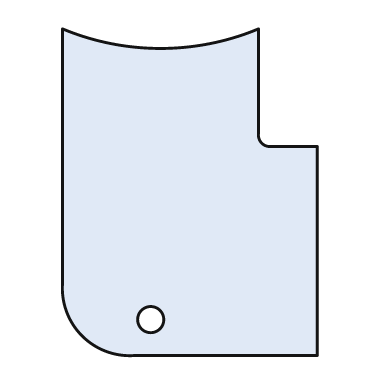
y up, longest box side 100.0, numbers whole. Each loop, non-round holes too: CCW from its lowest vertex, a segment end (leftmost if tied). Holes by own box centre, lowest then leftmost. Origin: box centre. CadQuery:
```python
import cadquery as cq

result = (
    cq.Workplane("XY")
    .moveTo(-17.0, -50.0)
    .lineTo(39.0, -50.0)
    .lineTo(39.0, 14.0)
    .lineTo(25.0, 14.0)
    .threePointArc((22.0, 15.0), (21.0, 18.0))
    .lineTo(21.0, 50.0)
    .threePointArc((-9.0, 44.0), (-39.0, 50.0))
    .lineTo(-39.0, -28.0)
    .threePointArc((-33.0, -44.0), (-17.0, -50.0))
    .close()
    .moveTo(-12.0, -39.0)
    .circle(4.0)
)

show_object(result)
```